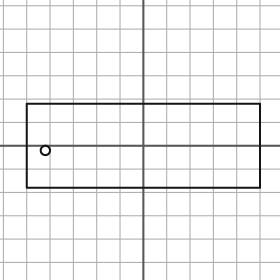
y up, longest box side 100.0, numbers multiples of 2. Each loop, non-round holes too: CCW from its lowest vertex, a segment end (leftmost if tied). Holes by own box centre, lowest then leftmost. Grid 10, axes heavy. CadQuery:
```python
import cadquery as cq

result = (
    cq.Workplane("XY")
    .moveTo(-50.0, -18.0)
    .lineTo(50.0, -18.0)
    .lineTo(50.0, 18.0)
    .lineTo(-50.0, 18.0)
    .close()
    .moveTo(-42.0, -2.0)
    .circle(2.0)
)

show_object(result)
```